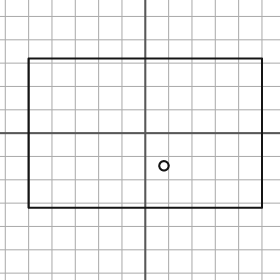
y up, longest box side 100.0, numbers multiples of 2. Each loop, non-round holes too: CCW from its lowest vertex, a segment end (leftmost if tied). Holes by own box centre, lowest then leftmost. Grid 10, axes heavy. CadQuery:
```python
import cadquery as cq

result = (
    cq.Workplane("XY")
    .moveTo(-50.0, -32.0)
    .lineTo(50.0, -32.0)
    .lineTo(50.0, 32.0)
    .lineTo(-50.0, 32.0)
    .close()
    .moveTo(8.0, -14.0)
    .circle(2.0)
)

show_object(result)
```